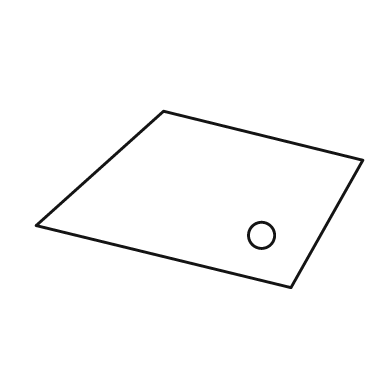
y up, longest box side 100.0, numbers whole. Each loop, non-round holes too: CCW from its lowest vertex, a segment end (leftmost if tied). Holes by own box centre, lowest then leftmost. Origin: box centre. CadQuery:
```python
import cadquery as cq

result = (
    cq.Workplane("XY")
    .moveTo(28.0, -27.0)
    .lineTo(50.0, 12.0)
    .lineTo(-11.0, 27.0)
    .lineTo(-50.0, -8.0)
    .close()
    .moveTo(19.0, -11.0)
    .circle(4.0)
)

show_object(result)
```